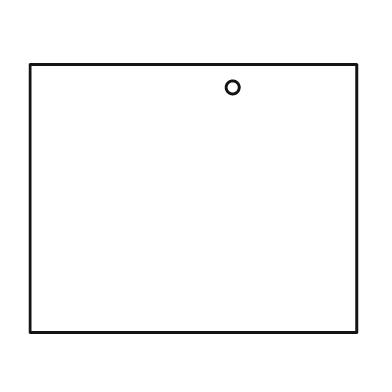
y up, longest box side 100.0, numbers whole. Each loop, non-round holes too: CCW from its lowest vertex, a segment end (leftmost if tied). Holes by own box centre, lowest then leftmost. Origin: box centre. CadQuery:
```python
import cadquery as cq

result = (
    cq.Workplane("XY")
    .moveTo(-50.0, -41.0)
    .lineTo(50.0, -41.0)
    .lineTo(50.0, 41.0)
    .lineTo(-50.0, 41.0)
    .close()
    .moveTo(12.0, 34.0)
    .circle(2.0)
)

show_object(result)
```